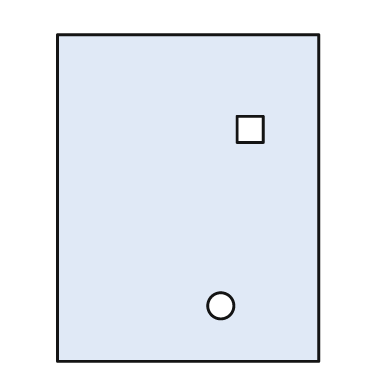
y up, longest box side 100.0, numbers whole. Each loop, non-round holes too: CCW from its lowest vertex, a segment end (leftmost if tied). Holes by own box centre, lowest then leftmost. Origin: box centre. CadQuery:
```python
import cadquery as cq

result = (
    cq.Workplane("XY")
    .moveTo(-40.0, -50.0)
    .lineTo(40.0, -50.0)
    .lineTo(40.0, 50.0)
    .lineTo(-40.0, 50.0)
    .close()
    .moveTo(10.0, -33.0)
    .circle(4.0)
    .moveTo(15.0, 17.0)
    .lineTo(23.0, 17.0)
    .lineTo(23.0, 25.0)
    .lineTo(15.0, 25.0)
    .close()
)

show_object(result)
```